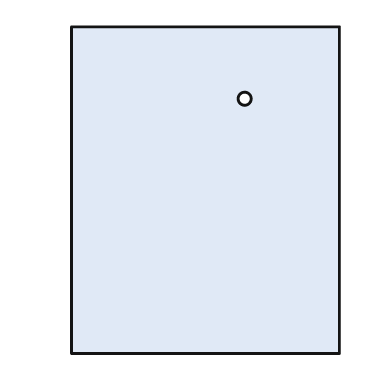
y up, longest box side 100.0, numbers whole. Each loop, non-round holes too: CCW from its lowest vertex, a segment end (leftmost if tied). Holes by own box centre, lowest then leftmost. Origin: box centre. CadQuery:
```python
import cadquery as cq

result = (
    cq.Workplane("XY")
    .moveTo(-41.0, -50.0)
    .lineTo(41.0, -50.0)
    .lineTo(41.0, 50.0)
    .lineTo(-41.0, 50.0)
    .close()
    .moveTo(12.0, 28.0)
    .circle(2.0)
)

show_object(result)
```